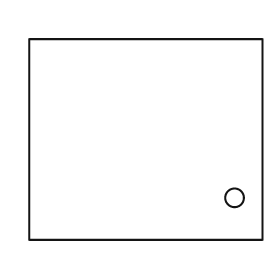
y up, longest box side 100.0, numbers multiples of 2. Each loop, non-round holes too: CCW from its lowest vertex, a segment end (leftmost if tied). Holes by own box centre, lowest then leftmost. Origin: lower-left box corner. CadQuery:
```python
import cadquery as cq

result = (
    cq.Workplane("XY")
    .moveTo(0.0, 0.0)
    .lineTo(100.0, 0.0)
    .lineTo(100.0, 86.0)
    .lineTo(0.0, 86.0)
    .close()
    .moveTo(88.0, 18.0)
    .circle(4.0)
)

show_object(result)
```